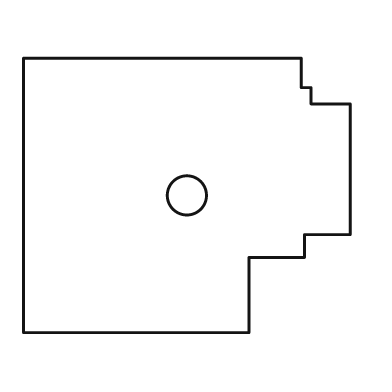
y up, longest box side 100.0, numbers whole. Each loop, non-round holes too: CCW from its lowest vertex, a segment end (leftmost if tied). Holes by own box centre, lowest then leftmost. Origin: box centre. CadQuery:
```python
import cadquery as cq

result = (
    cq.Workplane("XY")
    .moveTo(-50.0, -42.0)
    .lineTo(19.0, -42.0)
    .lineTo(19.0, -19.0)
    .lineTo(36.0, -19.0)
    .lineTo(36.0, -12.0)
    .lineTo(50.0, -12.0)
    .lineTo(50.0, 28.0)
    .lineTo(38.0, 28.0)
    .lineTo(38.0, 33.0)
    .lineTo(35.0, 33.0)
    .lineTo(35.0, 42.0)
    .lineTo(-50.0, 42.0)
    .close()
    .moveTo(0.0, 0.0)
    .circle(6.0)
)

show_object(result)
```